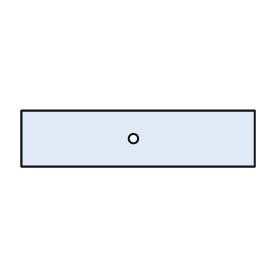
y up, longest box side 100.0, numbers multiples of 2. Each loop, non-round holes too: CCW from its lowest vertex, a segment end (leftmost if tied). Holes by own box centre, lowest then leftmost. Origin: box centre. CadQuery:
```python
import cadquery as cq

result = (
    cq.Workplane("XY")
    .moveTo(-50.0, -12.0)
    .lineTo(50.0, -12.0)
    .lineTo(50.0, 12.0)
    .lineTo(-50.0, 12.0)
    .close()
    .moveTo(-2.0, 0.0)
    .circle(2.0)
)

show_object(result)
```